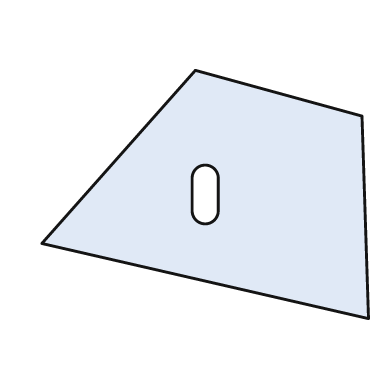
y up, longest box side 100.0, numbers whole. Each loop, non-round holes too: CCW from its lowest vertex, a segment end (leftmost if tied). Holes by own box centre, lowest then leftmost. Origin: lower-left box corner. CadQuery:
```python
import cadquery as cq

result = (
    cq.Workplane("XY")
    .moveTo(100.0, 0.0)
    .lineTo(98.0, 62.0)
    .lineTo(47.0, 76.0)
    .lineTo(0.0, 23.0)
    .close()
    .moveTo(46.0, 33.0)
    .threePointArc((50.0, 29.0), (54.0, 33.0))
    .lineTo(54.0, 43.0)
    .threePointArc((50.0, 47.0), (46.0, 43.0))
    .close()
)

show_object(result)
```